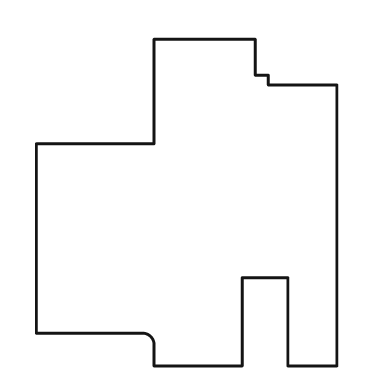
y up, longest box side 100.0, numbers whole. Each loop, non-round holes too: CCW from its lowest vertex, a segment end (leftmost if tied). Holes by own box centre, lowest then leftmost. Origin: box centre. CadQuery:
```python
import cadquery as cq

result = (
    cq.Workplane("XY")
    .moveTo(-10.0, -50.0)
    .lineTo(17.0, -50.0)
    .lineTo(17.0, -23.0)
    .lineTo(31.0, -23.0)
    .lineTo(31.0, -50.0)
    .lineTo(46.0, -50.0)
    .lineTo(46.0, 36.0)
    .lineTo(25.0, 36.0)
    .lineTo(25.0, 39.0)
    .lineTo(21.0, 39.0)
    .lineTo(21.0, 50.0)
    .lineTo(-10.0, 50.0)
    .lineTo(-10.0, 18.0)
    .lineTo(-46.0, 18.0)
    .lineTo(-46.0, -40.0)
    .lineTo(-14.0, -40.0)
    .threePointArc((-11.0, -41.0), (-10.0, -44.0))
    .close()
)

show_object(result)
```